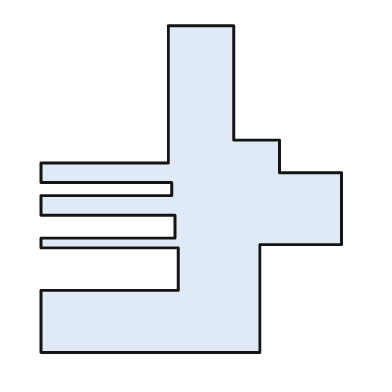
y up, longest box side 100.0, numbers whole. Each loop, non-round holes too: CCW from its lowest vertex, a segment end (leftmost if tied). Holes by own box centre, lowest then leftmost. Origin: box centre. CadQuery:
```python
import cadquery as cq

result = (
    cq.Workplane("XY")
    .moveTo(-46.0, -50.0)
    .lineTo(21.0, -50.0)
    .lineTo(21.0, -17.0)
    .lineTo(46.0, -17.0)
    .lineTo(46.0, 5.0)
    .lineTo(27.0, 5.0)
    .lineTo(27.0, 15.0)
    .lineTo(13.0, 15.0)
    .lineTo(13.0, 50.0)
    .lineTo(-7.0, 50.0)
    .lineTo(-7.0, 8.0)
    .lineTo(-46.0, 8.0)
    .lineTo(-46.0, 2.0)
    .lineTo(-6.0, 2.0)
    .lineTo(-6.0, -2.0)
    .lineTo(-46.0, -2.0)
    .lineTo(-46.0, -8.0)
    .lineTo(-5.0, -8.0)
    .lineTo(-5.0, -15.0)
    .lineTo(-46.0, -15.0)
    .lineTo(-46.0, -18.0)
    .lineTo(-4.0, -18.0)
    .lineTo(-4.0, -31.0)
    .lineTo(-46.0, -31.0)
    .close()
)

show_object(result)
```